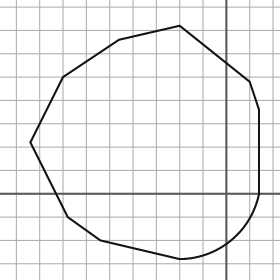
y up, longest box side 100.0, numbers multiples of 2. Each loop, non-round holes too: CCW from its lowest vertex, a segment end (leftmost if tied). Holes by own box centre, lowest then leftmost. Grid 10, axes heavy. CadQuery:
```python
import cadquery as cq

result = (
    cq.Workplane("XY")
    .moveTo(-20.0, -28.0)
    .threePointArc((2.0, -20.0), (14.0, 0.0))
    .lineTo(14.0, 36.0)
    .lineTo(10.0, 48.0)
    .lineTo(-20.0, 72.0)
    .lineTo(-46.0, 66.0)
    .lineTo(-70.0, 50.0)
    .lineTo(-84.0, 22.0)
    .lineTo(-68.0, -10.0)
    .lineTo(-54.0, -20.0)
    .close()
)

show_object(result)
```